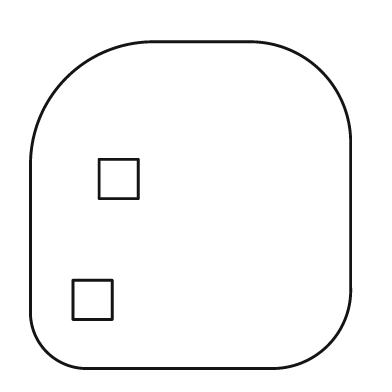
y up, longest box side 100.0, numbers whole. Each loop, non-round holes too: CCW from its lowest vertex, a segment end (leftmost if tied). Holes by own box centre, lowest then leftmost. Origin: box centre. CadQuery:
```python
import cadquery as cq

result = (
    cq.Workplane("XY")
    .moveTo(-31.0, -50.0)
    .lineTo(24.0, -50.0)
    .threePointArc((42.0, -43.0), (49.0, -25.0))
    .lineTo(49.0, 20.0)
    .threePointArc((40.0, 41.0), (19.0, 50.0))
    .lineTo(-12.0, 50.0)
    .threePointArc((-38.0, 39.0), (-49.0, 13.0))
    .lineTo(-49.0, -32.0)
    .threePointArc((-44.0, -45.0), (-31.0, -50.0))
    .close()
    .moveTo(-36.0, -35.0)
    .lineTo(-24.0, -35.0)
    .lineTo(-24.0, -23.0)
    .lineTo(-36.0, -23.0)
    .close()
    .moveTo(-28.0, 2.0)
    .lineTo(-16.0, 2.0)
    .lineTo(-16.0, 14.0)
    .lineTo(-28.0, 14.0)
    .close()
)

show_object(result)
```